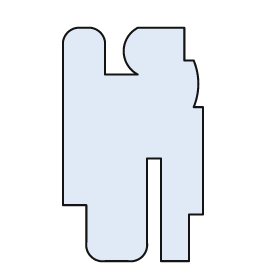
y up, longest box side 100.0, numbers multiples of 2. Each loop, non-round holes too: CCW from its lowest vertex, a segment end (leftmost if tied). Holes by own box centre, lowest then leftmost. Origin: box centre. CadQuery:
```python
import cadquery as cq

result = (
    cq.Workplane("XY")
    .moveTo(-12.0, -50.0)
    .lineTo(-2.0, -50.0)
    .threePointArc((4.0, -48.0), (6.0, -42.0))
    .lineTo(6.0, -6.0)
    .lineTo(12.0, -6.0)
    .lineTo(12.0, -50.0)
    .lineTo(24.0, -50.0)
    .lineTo(24.0, -30.0)
    .lineTo(30.0, -30.0)
    .lineTo(30.0, 16.0)
    .lineTo(26.0, 16.0)
    .threePointArc((28.0, 26.0), (26.0, 36.0))
    .lineTo(22.0, 36.0)
    .lineTo(22.0, 50.0)
    .lineTo(2.0, 50.0)
    .threePointArc((-4.0, 40.0), (2.0, 30.0))
    .lineTo(-12.0, 30.0)
    .lineTo(-12.0, 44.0)
    .threePointArc((-14.0, 48.0), (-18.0, 50.0))
    .lineTo(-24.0, 50.0)
    .threePointArc((-28.0, 48.0), (-30.0, 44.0))
    .lineTo(-30.0, -26.0)
    .lineTo(-20.0, -26.0)
    .lineTo(-20.0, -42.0)
    .threePointArc((-18.0, -48.0), (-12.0, -50.0))
    .close()
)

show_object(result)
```